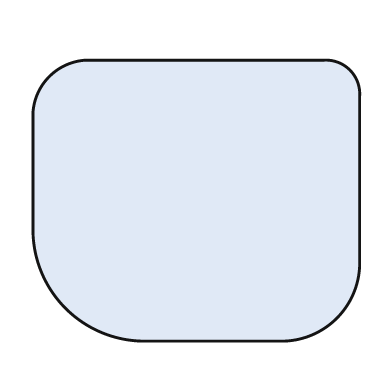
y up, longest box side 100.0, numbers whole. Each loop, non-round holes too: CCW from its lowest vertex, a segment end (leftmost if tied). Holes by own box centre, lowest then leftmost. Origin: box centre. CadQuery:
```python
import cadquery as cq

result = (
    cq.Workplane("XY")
    .moveTo(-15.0, -43.0)
    .lineTo(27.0, -43.0)
    .threePointArc((43.0, -36.0), (50.0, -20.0))
    .lineTo(50.0, 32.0)
    .threePointArc((47.0, 40.0), (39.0, 43.0))
    .lineTo(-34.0, 43.0)
    .threePointArc((-45.0, 38.0), (-50.0, 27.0))
    .lineTo(-50.0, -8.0)
    .threePointArc((-40.0, -33.0), (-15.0, -43.0))
    .close()
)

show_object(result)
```